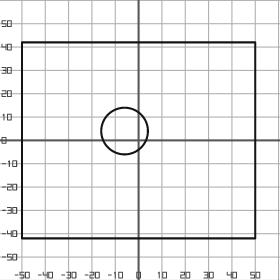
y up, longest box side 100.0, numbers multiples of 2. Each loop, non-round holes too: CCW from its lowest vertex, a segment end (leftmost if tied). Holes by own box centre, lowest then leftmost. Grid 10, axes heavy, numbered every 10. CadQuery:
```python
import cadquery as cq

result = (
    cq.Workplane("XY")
    .moveTo(-50.0, -42.0)
    .lineTo(50.0, -42.0)
    .lineTo(50.0, 42.0)
    .lineTo(-50.0, 42.0)
    .close()
    .moveTo(-6.0, 4.0)
    .circle(10.0)
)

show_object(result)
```